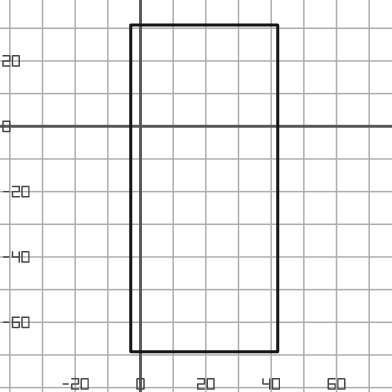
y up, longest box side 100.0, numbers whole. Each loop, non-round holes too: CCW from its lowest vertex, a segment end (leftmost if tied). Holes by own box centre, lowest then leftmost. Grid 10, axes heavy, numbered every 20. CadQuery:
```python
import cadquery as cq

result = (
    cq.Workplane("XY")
    .moveTo(-3.0, -69.0)
    .lineTo(42.0, -69.0)
    .lineTo(42.0, 31.0)
    .lineTo(-3.0, 31.0)
    .close()
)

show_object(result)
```